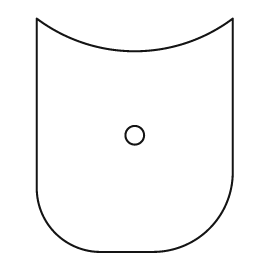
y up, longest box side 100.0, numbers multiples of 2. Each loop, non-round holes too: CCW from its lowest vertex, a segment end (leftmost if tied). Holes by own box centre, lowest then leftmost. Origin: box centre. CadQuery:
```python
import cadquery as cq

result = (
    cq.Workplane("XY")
    .moveTo(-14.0, -50.0)
    .lineTo(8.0, -50.0)
    .threePointArc((32.0, -40.0), (42.0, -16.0))
    .lineTo(42.0, 50.0)
    .threePointArc((0.0, 36.0), (-42.0, 50.0))
    .lineTo(-42.0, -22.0)
    .threePointArc((-34.0, -42.0), (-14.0, -50.0))
    .close()
    .moveTo(0.0, 0.0)
    .circle(4.0)
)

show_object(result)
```